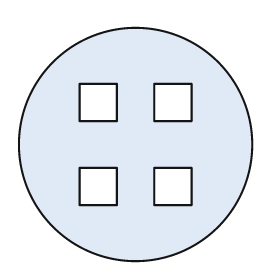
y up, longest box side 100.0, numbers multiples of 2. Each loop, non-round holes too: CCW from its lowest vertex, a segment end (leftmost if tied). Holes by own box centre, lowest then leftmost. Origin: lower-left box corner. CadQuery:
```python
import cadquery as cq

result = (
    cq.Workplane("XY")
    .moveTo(50.0, 50.0)
    .circle(50.0)
    .moveTo(26.0, 24.0)
    .lineTo(42.0, 24.0)
    .lineTo(42.0, 40.0)
    .lineTo(26.0, 40.0)
    .close()
    .moveTo(58.0, 24.0)
    .lineTo(74.0, 24.0)
    .lineTo(74.0, 40.0)
    .lineTo(58.0, 40.0)
    .close()
    .moveTo(26.0, 60.0)
    .lineTo(42.0, 60.0)
    .lineTo(42.0, 76.0)
    .lineTo(26.0, 76.0)
    .close()
    .moveTo(58.0, 60.0)
    .lineTo(74.0, 60.0)
    .lineTo(74.0, 76.0)
    .lineTo(58.0, 76.0)
    .close()
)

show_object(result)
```